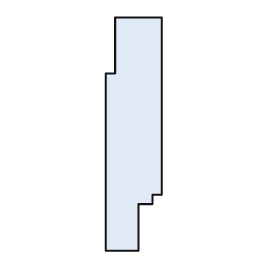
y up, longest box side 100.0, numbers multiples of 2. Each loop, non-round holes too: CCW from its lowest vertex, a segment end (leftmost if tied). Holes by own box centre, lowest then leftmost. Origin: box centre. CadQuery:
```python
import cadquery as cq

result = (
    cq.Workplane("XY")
    .moveTo(-12.0, -50.0)
    .lineTo(2.0, -50.0)
    .lineTo(2.0, -30.0)
    .lineTo(8.0, -30.0)
    .lineTo(8.0, -26.0)
    .lineTo(12.0, -26.0)
    .lineTo(12.0, 50.0)
    .lineTo(-8.0, 50.0)
    .lineTo(-8.0, 26.0)
    .lineTo(-12.0, 26.0)
    .close()
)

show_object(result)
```